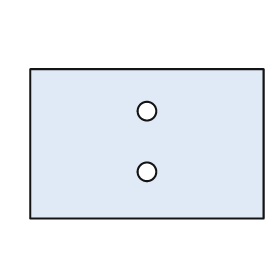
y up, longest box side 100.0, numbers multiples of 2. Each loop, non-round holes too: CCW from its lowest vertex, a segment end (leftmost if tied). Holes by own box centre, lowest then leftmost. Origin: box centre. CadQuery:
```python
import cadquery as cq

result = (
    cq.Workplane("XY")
    .moveTo(-50.0, -32.0)
    .lineTo(50.0, -32.0)
    .lineTo(50.0, 32.0)
    .lineTo(-50.0, 32.0)
    .close()
    .moveTo(0.0, -12.0)
    .circle(4.0)
    .moveTo(0.0, 14.0)
    .circle(4.0)
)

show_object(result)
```